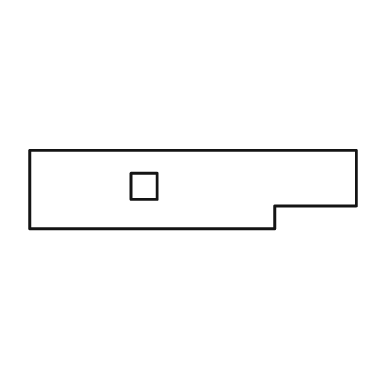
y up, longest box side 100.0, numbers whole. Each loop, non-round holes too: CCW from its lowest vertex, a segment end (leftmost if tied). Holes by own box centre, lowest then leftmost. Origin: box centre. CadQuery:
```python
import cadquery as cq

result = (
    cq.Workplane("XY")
    .moveTo(-50.0, -12.0)
    .lineTo(25.0, -12.0)
    .lineTo(25.0, -5.0)
    .lineTo(50.0, -5.0)
    .lineTo(50.0, 12.0)
    .lineTo(-50.0, 12.0)
    .close()
    .moveTo(-19.0, -3.0)
    .lineTo(-11.0, -3.0)
    .lineTo(-11.0, 5.0)
    .lineTo(-19.0, 5.0)
    .close()
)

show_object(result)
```